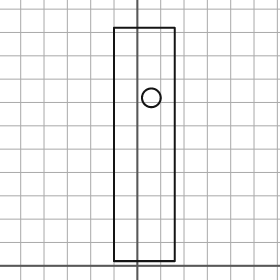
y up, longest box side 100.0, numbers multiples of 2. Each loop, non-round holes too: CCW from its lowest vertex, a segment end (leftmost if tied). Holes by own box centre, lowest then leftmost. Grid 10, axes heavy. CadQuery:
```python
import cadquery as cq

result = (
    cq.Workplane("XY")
    .moveTo(-10.0, 2.0)
    .lineTo(16.0, 2.0)
    .lineTo(16.0, 102.0)
    .lineTo(-10.0, 102.0)
    .close()
    .moveTo(6.0, 72.0)
    .circle(4.0)
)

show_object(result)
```